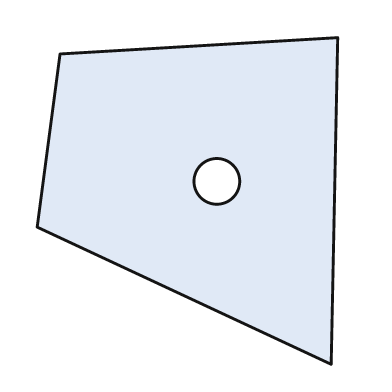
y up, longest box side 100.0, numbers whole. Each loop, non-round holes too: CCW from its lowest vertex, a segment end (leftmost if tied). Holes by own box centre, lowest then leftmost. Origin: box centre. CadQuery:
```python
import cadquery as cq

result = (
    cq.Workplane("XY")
    .moveTo(44.0, -50.0)
    .lineTo(46.0, 50.0)
    .lineTo(-39.0, 45.0)
    .lineTo(-46.0, -8.0)
    .close()
    .moveTo(9.0, 6.0)
    .circle(7.0)
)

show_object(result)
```